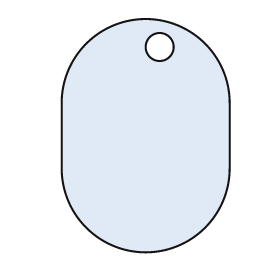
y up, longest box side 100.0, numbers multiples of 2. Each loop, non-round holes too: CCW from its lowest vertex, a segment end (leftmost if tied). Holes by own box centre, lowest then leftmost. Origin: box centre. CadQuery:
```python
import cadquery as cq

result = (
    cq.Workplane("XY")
    .moveTo(-36.0, -14.0)
    .threePointArc((0.0, -50.0), (36.0, -14.0))
    .lineTo(36.0, 14.0)
    .threePointArc((0.0, 50.0), (-36.0, 14.0))
    .close()
    .moveTo(6.0, 38.0)
    .circle(6.0)
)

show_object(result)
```